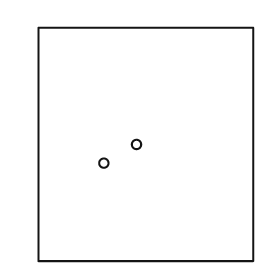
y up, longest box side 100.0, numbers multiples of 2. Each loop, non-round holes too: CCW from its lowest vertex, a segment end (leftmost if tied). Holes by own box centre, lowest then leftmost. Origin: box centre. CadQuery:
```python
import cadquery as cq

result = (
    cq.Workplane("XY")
    .moveTo(-46.0, -50.0)
    .lineTo(46.0, -50.0)
    .lineTo(46.0, 50.0)
    .lineTo(-46.0, 50.0)
    .close()
    .moveTo(-18.0, -8.0)
    .circle(2.0)
    .moveTo(-4.0, 0.0)
    .circle(2.0)
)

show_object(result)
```